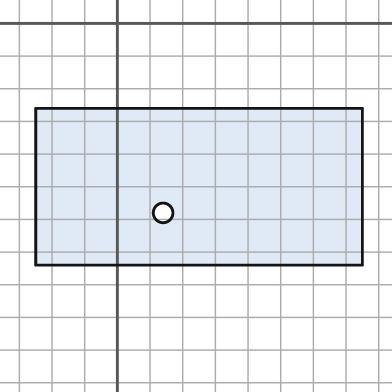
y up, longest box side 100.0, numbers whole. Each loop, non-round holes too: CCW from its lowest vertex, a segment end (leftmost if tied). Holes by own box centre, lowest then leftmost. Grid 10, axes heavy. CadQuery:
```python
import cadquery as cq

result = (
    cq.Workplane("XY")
    .moveTo(-25.0, -74.0)
    .lineTo(75.0, -74.0)
    .lineTo(75.0, -26.0)
    .lineTo(-25.0, -26.0)
    .close()
    .moveTo(14.0, -58.0)
    .circle(3.0)
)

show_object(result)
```